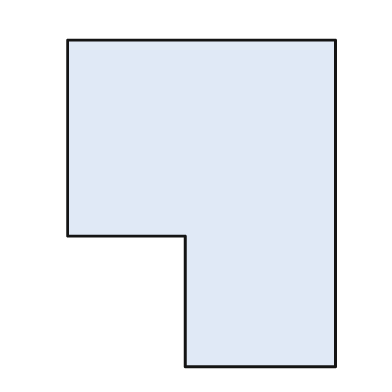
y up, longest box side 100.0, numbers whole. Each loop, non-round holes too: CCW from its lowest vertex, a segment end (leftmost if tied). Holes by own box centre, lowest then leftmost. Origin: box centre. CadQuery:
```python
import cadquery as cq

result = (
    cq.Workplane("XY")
    .moveTo(-5.0, -50.0)
    .lineTo(41.0, -50.0)
    .lineTo(41.0, 50.0)
    .lineTo(-41.0, 50.0)
    .lineTo(-41.0, -10.0)
    .lineTo(-5.0, -10.0)
    .close()
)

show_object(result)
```